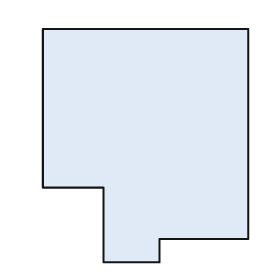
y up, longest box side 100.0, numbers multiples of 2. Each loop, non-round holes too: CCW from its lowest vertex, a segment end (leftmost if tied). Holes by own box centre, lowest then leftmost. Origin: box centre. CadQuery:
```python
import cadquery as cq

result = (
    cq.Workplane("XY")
    .moveTo(-18.0, -50.0)
    .lineTo(6.0, -50.0)
    .lineTo(6.0, -40.0)
    .lineTo(44.0, -40.0)
    .lineTo(44.0, 50.0)
    .lineTo(-44.0, 50.0)
    .lineTo(-44.0, -18.0)
    .lineTo(-18.0, -18.0)
    .close()
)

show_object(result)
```